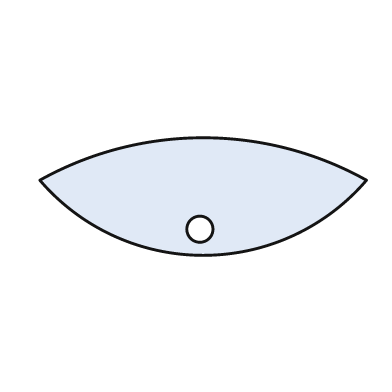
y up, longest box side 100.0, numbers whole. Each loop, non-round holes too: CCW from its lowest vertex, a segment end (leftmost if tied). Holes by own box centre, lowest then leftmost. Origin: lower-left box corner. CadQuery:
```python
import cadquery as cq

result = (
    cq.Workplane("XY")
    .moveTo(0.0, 23.0)
    .threePointArc((50.0, 0.0), (100.0, 23.0))
    .threePointArc((50.0, 36.0), (0.0, 23.0))
    .close()
    .moveTo(49.0, 8.0)
    .circle(4.0)
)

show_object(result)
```